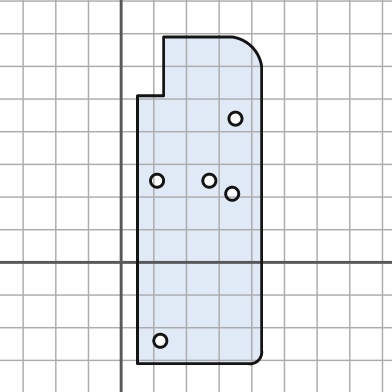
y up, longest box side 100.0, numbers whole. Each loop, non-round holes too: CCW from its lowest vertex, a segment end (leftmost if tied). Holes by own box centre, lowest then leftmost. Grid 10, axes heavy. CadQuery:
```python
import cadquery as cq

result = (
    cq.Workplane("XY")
    .moveTo(5.0, -31.0)
    .lineTo(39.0, -31.0)
    .threePointArc((42.0, -30.0), (43.0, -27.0))
    .lineTo(43.0, 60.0)
    .threePointArc((40.0, 66.0), (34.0, 69.0))
    .lineTo(13.0, 69.0)
    .lineTo(13.0, 51.0)
    .lineTo(5.0, 51.0)
    .close()
    .moveTo(12.0, -24.0)
    .circle(2.0)
    .moveTo(34.0, 21.0)
    .circle(2.0)
    .moveTo(11.0, 25.0)
    .circle(2.0)
    .moveTo(27.0, 25.0)
    .circle(2.0)
    .moveTo(35.0, 44.0)
    .circle(2.0)
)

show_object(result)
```